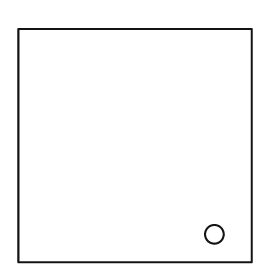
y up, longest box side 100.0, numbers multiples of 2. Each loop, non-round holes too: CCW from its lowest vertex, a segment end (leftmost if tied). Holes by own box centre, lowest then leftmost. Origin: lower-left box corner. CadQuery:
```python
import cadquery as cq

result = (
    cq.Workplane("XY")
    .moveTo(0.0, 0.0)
    .lineTo(100.0, 0.0)
    .lineTo(100.0, 100.0)
    .lineTo(0.0, 100.0)
    .close()
    .moveTo(84.0, 12.0)
    .circle(4.0)
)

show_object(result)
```